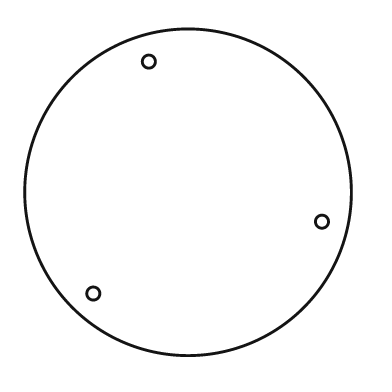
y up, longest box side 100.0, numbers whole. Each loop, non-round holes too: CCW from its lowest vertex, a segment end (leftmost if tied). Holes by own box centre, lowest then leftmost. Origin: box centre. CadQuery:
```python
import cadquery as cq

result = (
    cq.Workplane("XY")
    .moveTo(0.0, 0.0)
    .circle(50.0)
    .moveTo(-29.0, -31.0)
    .circle(2.0)
    .moveTo(41.0, -9.0)
    .circle(2.0)
    .moveTo(-12.0, 40.0)
    .circle(2.0)
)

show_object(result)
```